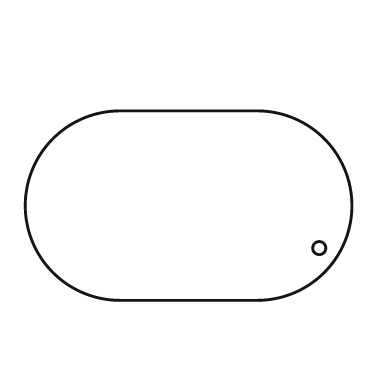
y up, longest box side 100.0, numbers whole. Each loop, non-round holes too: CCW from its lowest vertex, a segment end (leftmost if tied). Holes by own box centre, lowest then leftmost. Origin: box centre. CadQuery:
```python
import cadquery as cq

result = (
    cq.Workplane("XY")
    .moveTo(-21.0, -29.0)
    .lineTo(21.0, -29.0)
    .threePointArc((50.0, 0.0), (21.0, 29.0))
    .lineTo(-21.0, 29.0)
    .threePointArc((-50.0, 0.0), (-21.0, -29.0))
    .close()
    .moveTo(40.0, -13.0)
    .circle(2.0)
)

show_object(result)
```